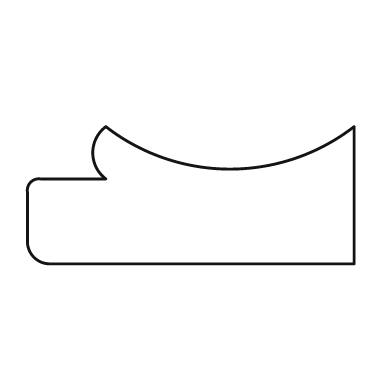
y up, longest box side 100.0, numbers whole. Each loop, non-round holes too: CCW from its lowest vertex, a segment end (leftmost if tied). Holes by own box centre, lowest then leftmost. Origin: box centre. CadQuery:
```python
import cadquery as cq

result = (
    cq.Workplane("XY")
    .moveTo(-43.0, -21.0)
    .lineTo(50.0, -21.0)
    .lineTo(50.0, 21.0)
    .threePointArc((12.0, 8.0), (-26.0, 21.0))
    .threePointArc((-30.0, 13.0), (-26.0, 5.0))
    .lineTo(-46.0, 5.0)
    .threePointArc((-49.0, 4.0), (-50.0, 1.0))
    .lineTo(-50.0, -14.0)
    .threePointArc((-48.0, -19.0), (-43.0, -21.0))
    .close()
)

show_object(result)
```